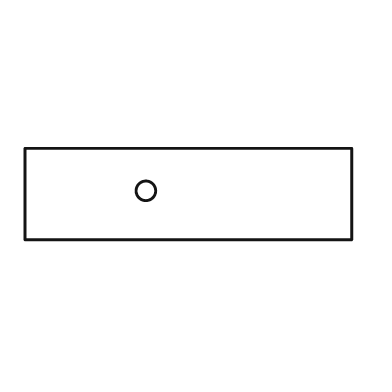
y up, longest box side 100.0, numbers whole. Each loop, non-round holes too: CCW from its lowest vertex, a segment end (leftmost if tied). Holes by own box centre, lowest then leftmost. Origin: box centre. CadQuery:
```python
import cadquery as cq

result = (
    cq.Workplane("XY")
    .moveTo(-50.0, -14.0)
    .lineTo(50.0, -14.0)
    .lineTo(50.0, 14.0)
    .lineTo(-50.0, 14.0)
    .close()
    .moveTo(-13.0, 1.0)
    .circle(3.0)
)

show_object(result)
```